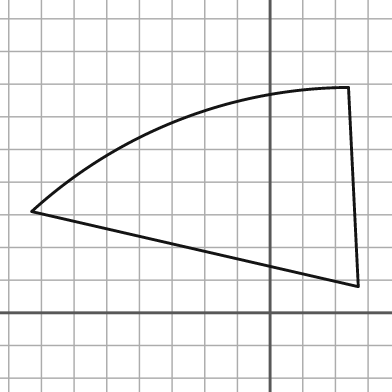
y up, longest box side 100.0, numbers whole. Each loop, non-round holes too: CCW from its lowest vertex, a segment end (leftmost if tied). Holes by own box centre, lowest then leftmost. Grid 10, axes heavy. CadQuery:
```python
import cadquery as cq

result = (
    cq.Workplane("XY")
    .moveTo(27.0, 8.0)
    .lineTo(24.0, 69.0)
    .threePointArc((-28.0, 59.0), (-73.0, 31.0))
    .close()
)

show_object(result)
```